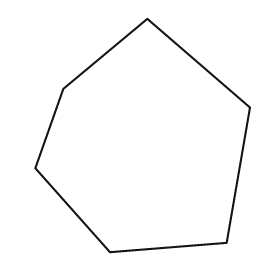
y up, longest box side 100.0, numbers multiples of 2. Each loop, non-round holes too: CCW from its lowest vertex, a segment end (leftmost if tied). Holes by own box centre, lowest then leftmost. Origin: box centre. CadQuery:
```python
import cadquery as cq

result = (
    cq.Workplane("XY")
    .moveTo(-14.0, -50.0)
    .lineTo(36.0, -46.0)
    .lineTo(46.0, 12.0)
    .lineTo(2.0, 50.0)
    .lineTo(-34.0, 20.0)
    .lineTo(-46.0, -14.0)
    .close()
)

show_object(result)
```